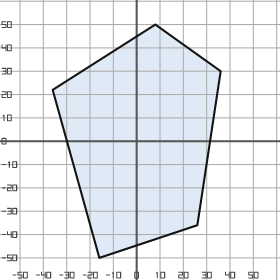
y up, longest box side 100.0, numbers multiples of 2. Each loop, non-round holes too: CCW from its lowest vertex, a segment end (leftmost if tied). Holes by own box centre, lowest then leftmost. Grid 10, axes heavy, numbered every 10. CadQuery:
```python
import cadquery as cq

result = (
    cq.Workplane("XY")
    .moveTo(-16.0, -50.0)
    .lineTo(26.0, -36.0)
    .lineTo(36.0, 30.0)
    .lineTo(8.0, 50.0)
    .lineTo(-36.0, 22.0)
    .close()
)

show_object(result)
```